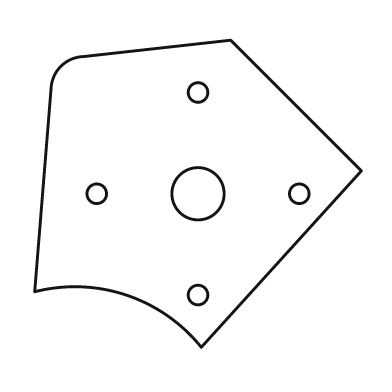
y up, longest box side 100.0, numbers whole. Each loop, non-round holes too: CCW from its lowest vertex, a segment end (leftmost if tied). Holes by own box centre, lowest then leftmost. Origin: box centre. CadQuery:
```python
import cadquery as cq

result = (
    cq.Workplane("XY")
    .moveTo(1.0, -47.0)
    .lineTo(50.0, 7.0)
    .lineTo(10.0, 47.0)
    .lineTo(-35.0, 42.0)
    .threePointArc((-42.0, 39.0), (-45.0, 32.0))
    .lineTo(-50.0, -30.0)
    .threePointArc((-22.0, -31.0), (1.0, -47.0))
    .close()
    .moveTo(0.0, -31.0)
    .circle(3.0)
    .moveTo(-31.0, 0.0)
    .circle(3.0)
    .moveTo(0.0, 0.0)
    .circle(8.0)
    .moveTo(31.0, 0.0)
    .circle(3.0)
    .moveTo(0.0, 31.0)
    .circle(3.0)
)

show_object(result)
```